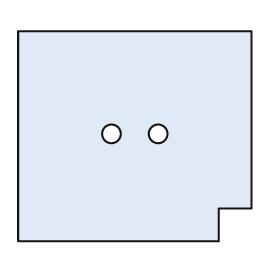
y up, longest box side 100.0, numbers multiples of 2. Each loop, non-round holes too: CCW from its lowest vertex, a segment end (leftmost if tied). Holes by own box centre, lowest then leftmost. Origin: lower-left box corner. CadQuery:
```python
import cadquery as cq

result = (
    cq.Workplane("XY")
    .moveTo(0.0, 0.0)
    .lineTo(86.0, 0.0)
    .lineTo(86.0, 14.0)
    .lineTo(100.0, 14.0)
    .lineTo(100.0, 90.0)
    .lineTo(0.0, 90.0)
    .close()
    .moveTo(40.0, 46.0)
    .circle(4.0)
    .moveTo(60.0, 46.0)
    .circle(4.0)
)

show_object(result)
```